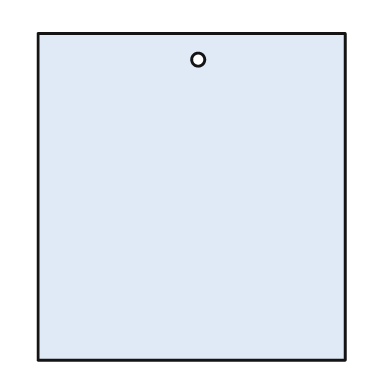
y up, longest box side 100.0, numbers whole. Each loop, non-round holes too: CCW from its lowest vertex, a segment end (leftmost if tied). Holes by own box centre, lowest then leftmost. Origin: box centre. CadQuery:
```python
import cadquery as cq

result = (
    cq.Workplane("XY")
    .moveTo(-47.0, -50.0)
    .lineTo(47.0, -50.0)
    .lineTo(47.0, 50.0)
    .lineTo(-47.0, 50.0)
    .close()
    .moveTo(2.0, 42.0)
    .circle(2.0)
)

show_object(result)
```